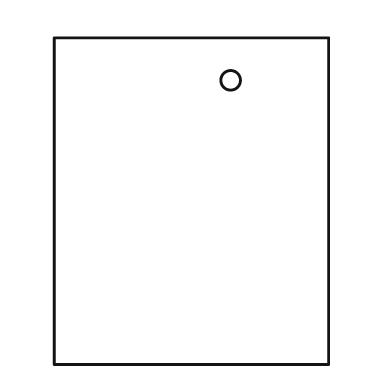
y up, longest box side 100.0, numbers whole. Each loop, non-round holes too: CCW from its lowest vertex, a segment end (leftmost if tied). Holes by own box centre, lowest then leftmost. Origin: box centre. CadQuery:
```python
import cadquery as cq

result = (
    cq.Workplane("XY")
    .moveTo(-42.0, -50.0)
    .lineTo(42.0, -50.0)
    .lineTo(42.0, 50.0)
    .lineTo(-42.0, 50.0)
    .close()
    .moveTo(12.0, 37.0)
    .circle(3.0)
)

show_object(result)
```